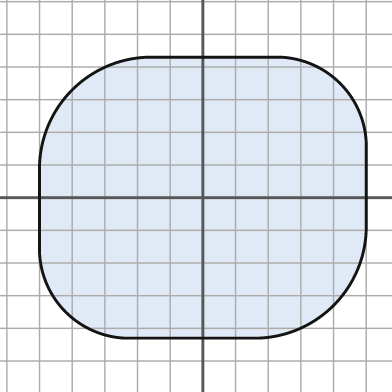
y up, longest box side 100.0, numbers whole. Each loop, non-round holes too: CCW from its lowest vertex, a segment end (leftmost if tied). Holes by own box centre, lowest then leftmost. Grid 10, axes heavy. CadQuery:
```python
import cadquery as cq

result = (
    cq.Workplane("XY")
    .moveTo(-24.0, -43.0)
    .lineTo(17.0, -43.0)
    .threePointArc((40.0, -33.0), (50.0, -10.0))
    .lineTo(50.0, 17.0)
    .threePointArc((42.0, 35.0), (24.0, 43.0))
    .lineTo(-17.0, 43.0)
    .threePointArc((-40.0, 33.0), (-50.0, 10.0))
    .lineTo(-50.0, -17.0)
    .threePointArc((-42.0, -35.0), (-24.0, -43.0))
    .close()
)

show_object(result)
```